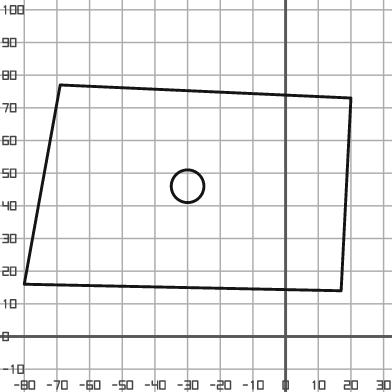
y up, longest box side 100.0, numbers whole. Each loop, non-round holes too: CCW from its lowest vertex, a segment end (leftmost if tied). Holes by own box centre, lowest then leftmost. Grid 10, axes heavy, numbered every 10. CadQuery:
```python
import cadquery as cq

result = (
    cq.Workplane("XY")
    .moveTo(17.0, 14.0)
    .lineTo(20.0, 73.0)
    .lineTo(-69.0, 77.0)
    .lineTo(-80.0, 16.0)
    .close()
    .moveTo(-30.0, 46.0)
    .circle(5.0)
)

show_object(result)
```